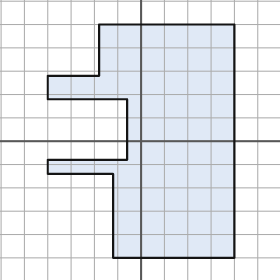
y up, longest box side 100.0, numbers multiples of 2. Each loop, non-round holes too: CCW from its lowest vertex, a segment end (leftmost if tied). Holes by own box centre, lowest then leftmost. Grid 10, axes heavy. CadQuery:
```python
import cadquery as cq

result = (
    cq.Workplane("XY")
    .moveTo(-12.0, -50.0)
    .lineTo(40.0, -50.0)
    .lineTo(40.0, 50.0)
    .lineTo(-18.0, 50.0)
    .lineTo(-18.0, 28.0)
    .lineTo(-40.0, 28.0)
    .lineTo(-40.0, 18.0)
    .lineTo(-6.0, 18.0)
    .lineTo(-6.0, -8.0)
    .lineTo(-40.0, -8.0)
    .lineTo(-40.0, -14.0)
    .lineTo(-12.0, -14.0)
    .close()
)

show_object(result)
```